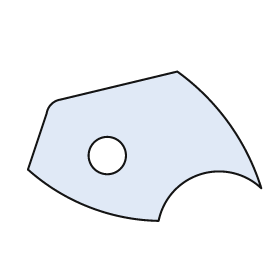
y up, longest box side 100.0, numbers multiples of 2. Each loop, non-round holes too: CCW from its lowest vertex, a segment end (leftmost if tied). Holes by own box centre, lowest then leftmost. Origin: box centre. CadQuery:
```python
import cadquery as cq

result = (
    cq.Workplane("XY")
    .moveTo(6.0, -32.0)
    .threePointArc((24.0, -12.0), (50.0, -18.0))
    .threePointArc((36.0, 10.0), (14.0, 32.0))
    .lineTo(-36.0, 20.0)
    .threePointArc((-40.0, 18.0), (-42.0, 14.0))
    .lineTo(-50.0, -10.0)
    .threePointArc((-24.0, -26.0), (6.0, -32.0))
    .close()
    .moveTo(-16.0, -4.0)
    .circle(8.0)
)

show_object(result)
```